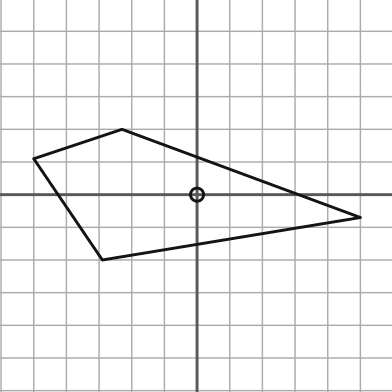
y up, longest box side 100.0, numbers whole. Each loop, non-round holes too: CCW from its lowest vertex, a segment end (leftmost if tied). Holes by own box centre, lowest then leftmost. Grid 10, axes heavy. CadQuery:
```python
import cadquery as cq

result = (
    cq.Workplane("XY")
    .moveTo(-29.0, -20.0)
    .lineTo(50.0, -7.0)
    .lineTo(-23.0, 20.0)
    .lineTo(-50.0, 11.0)
    .close()
    .moveTo(0.0, 0.0)
    .circle(2.0)
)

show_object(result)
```